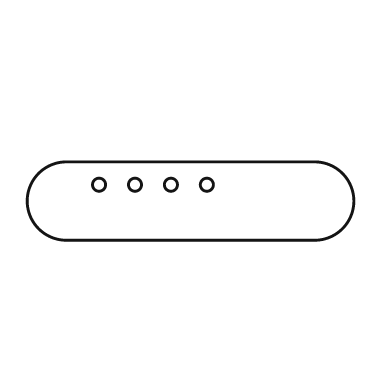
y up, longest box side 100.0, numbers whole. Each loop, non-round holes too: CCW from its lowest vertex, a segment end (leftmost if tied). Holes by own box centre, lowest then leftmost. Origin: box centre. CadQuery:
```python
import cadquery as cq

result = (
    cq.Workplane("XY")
    .moveTo(-38.0, -12.0)
    .lineTo(38.0, -12.0)
    .threePointArc((50.0, 0.0), (38.0, 12.0))
    .lineTo(-38.0, 12.0)
    .threePointArc((-50.0, 0.0), (-38.0, -12.0))
    .close()
    .moveTo(-28.0, 5.0)
    .circle(2.0)
    .moveTo(-17.0, 5.0)
    .circle(2.0)
    .moveTo(-6.0, 5.0)
    .circle(2.0)
    .moveTo(5.0, 5.0)
    .circle(2.0)
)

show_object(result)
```